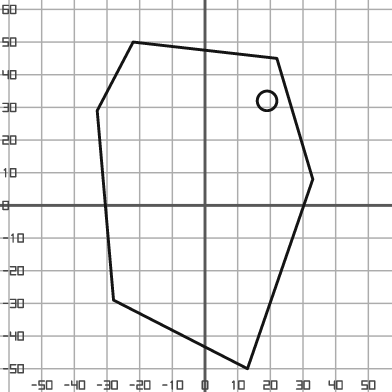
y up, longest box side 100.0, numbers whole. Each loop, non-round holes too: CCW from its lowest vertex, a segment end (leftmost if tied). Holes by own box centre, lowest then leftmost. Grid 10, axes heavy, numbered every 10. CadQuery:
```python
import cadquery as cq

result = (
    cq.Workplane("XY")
    .moveTo(13.0, -50.0)
    .lineTo(33.0, 8.0)
    .lineTo(22.0, 45.0)
    .lineTo(-22.0, 50.0)
    .lineTo(-33.0, 29.0)
    .lineTo(-28.0, -29.0)
    .close()
    .moveTo(19.0, 32.0)
    .circle(3.0)
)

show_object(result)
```